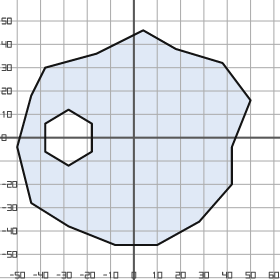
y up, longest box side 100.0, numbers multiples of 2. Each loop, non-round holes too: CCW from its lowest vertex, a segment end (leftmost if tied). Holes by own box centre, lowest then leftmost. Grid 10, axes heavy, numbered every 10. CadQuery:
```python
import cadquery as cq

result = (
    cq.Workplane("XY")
    .moveTo(-8.0, -46.0)
    .lineTo(10.0, -46.0)
    .lineTo(28.0, -36.0)
    .lineTo(42.0, -20.0)
    .lineTo(42.0, -4.0)
    .lineTo(50.0, 16.0)
    .lineTo(38.0, 32.0)
    .lineTo(18.0, 38.0)
    .lineTo(4.0, 46.0)
    .lineTo(-16.0, 36.0)
    .lineTo(-38.0, 30.0)
    .lineTo(-44.0, 18.0)
    .lineTo(-50.0, -4.0)
    .lineTo(-44.0, -28.0)
    .lineTo(-28.0, -38.0)
    .close()
    .moveTo(-28.0, -12.0)
    .lineTo(-18.0, -6.0)
    .lineTo(-18.0, 6.0)
    .lineTo(-28.0, 12.0)
    .lineTo(-38.0, 6.0)
    .lineTo(-38.0, -6.0)
    .close()
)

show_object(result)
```